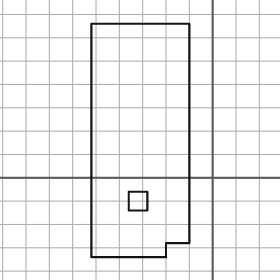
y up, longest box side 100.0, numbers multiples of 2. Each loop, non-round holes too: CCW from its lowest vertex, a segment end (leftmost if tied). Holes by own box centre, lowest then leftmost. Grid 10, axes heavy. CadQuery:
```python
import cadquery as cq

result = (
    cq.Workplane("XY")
    .moveTo(-52.0, -34.0)
    .lineTo(-20.0, -34.0)
    .lineTo(-20.0, -28.0)
    .lineTo(-10.0, -28.0)
    .lineTo(-10.0, 66.0)
    .lineTo(-52.0, 66.0)
    .close()
    .moveTo(-36.0, -14.0)
    .lineTo(-28.0, -14.0)
    .lineTo(-28.0, -6.0)
    .lineTo(-36.0, -6.0)
    .close()
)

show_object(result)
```